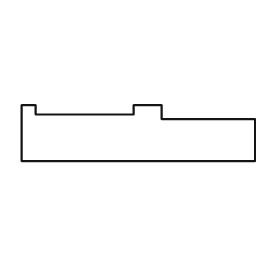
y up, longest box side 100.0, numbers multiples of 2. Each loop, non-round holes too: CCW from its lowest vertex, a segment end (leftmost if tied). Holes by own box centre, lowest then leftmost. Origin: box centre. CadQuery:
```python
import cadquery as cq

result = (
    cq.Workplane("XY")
    .moveTo(-50.0, -12.0)
    .lineTo(50.0, -12.0)
    .lineTo(50.0, 6.0)
    .lineTo(10.0, 6.0)
    .lineTo(10.0, 12.0)
    .lineTo(-2.0, 12.0)
    .lineTo(-2.0, 8.0)
    .lineTo(-44.0, 8.0)
    .lineTo(-44.0, 12.0)
    .lineTo(-50.0, 12.0)
    .close()
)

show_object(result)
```